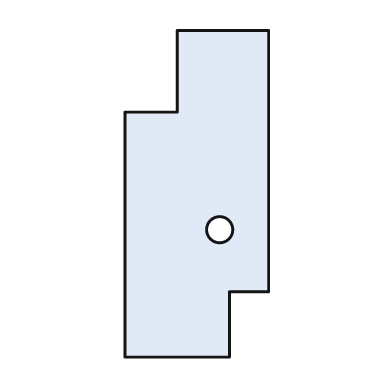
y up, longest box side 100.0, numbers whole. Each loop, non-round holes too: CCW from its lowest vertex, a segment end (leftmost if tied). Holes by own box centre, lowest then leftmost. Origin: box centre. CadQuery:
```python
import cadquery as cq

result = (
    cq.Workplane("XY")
    .moveTo(-22.0, -50.0)
    .lineTo(10.0, -50.0)
    .lineTo(10.0, -30.0)
    .lineTo(22.0, -30.0)
    .lineTo(22.0, 50.0)
    .lineTo(-6.0, 50.0)
    .lineTo(-6.0, 25.0)
    .lineTo(-22.0, 25.0)
    .close()
    .moveTo(7.0, -11.0)
    .circle(4.0)
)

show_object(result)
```